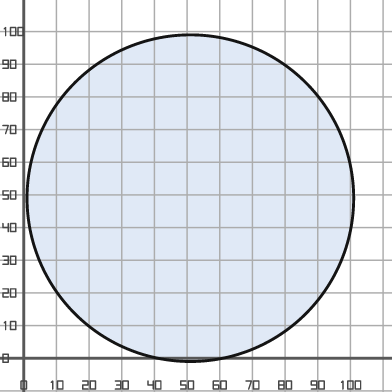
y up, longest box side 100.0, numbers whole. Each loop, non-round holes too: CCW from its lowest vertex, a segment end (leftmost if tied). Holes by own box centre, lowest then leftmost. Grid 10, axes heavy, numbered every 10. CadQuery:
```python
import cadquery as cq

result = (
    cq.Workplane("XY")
    .moveTo(51.0, 49.0)
    .circle(50.0)
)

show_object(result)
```